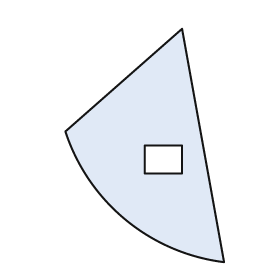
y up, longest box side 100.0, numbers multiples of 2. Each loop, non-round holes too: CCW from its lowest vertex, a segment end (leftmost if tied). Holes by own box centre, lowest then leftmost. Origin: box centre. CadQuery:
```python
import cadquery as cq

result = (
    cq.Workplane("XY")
    .moveTo(34.0, -50.0)
    .lineTo(16.0, 50.0)
    .lineTo(-34.0, 6.0)
    .threePointArc((-8.0, -32.0), (34.0, -50.0))
    .close()
    .moveTo(0.0, -12.0)
    .lineTo(16.0, -12.0)
    .lineTo(16.0, 0.0)
    .lineTo(0.0, 0.0)
    .close()
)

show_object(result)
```